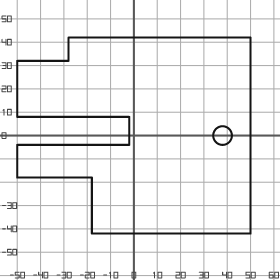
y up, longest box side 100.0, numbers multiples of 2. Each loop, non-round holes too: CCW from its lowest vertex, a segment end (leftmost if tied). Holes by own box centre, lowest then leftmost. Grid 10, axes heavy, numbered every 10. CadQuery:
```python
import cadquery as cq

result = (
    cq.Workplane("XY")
    .moveTo(-18.0, -42.0)
    .lineTo(50.0, -42.0)
    .lineTo(50.0, 42.0)
    .lineTo(-28.0, 42.0)
    .lineTo(-28.0, 32.0)
    .lineTo(-50.0, 32.0)
    .lineTo(-50.0, 8.0)
    .lineTo(-2.0, 8.0)
    .lineTo(-2.0, -4.0)
    .lineTo(-50.0, -4.0)
    .lineTo(-50.0, -18.0)
    .lineTo(-18.0, -18.0)
    .close()
    .moveTo(38.0, 0.0)
    .circle(4.0)
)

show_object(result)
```